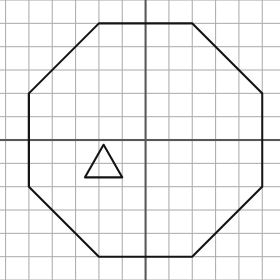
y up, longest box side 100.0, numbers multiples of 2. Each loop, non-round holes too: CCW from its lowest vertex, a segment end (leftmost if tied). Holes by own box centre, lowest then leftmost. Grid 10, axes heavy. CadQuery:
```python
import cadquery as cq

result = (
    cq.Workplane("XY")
    .moveTo(-20.0, -50.0)
    .lineTo(20.0, -50.0)
    .lineTo(50.0, -20.0)
    .lineTo(50.0, 20.0)
    .lineTo(20.0, 50.0)
    .lineTo(-20.0, 50.0)
    .lineTo(-50.0, 20.0)
    .lineTo(-50.0, -20.0)
    .close()
    .moveTo(-26.0, -16.0)
    .lineTo(-10.0, -16.0)
    .lineTo(-18.0, -2.0)
    .close()
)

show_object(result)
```